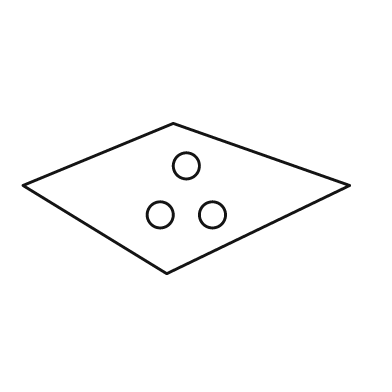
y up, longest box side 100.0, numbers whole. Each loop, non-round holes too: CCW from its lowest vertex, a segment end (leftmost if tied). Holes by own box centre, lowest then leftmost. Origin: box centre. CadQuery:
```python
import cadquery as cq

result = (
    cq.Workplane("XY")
    .moveTo(-6.0, -23.0)
    .lineTo(50.0, 4.0)
    .lineTo(-4.0, 23.0)
    .lineTo(-50.0, 4.0)
    .close()
    .moveTo(-8.0, -5.0)
    .circle(4.0)
    .moveTo(8.0, -5.0)
    .circle(4.0)
    .moveTo(0.0, 10.0)
    .circle(4.0)
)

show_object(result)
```